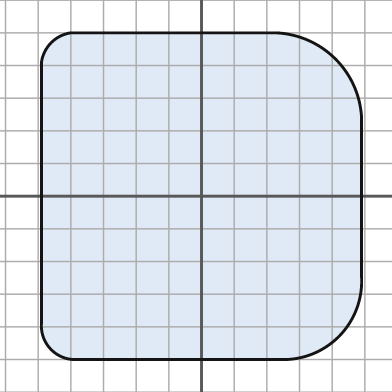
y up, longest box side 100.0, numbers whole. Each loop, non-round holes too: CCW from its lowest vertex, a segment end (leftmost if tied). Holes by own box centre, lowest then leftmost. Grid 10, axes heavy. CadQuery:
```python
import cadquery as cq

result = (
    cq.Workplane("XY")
    .moveTo(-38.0, -50.0)
    .lineTo(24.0, -50.0)
    .threePointArc((42.0, -43.0), (49.0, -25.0))
    .lineTo(49.0, 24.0)
    .threePointArc((41.0, 42.0), (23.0, 50.0))
    .lineTo(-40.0, 50.0)
    .threePointArc((-46.0, 47.0), (-49.0, 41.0))
    .lineTo(-49.0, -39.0)
    .threePointArc((-46.0, -47.0), (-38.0, -50.0))
    .close()
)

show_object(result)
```